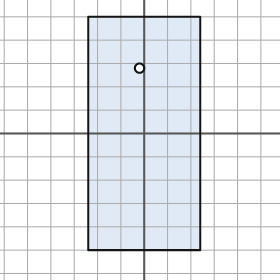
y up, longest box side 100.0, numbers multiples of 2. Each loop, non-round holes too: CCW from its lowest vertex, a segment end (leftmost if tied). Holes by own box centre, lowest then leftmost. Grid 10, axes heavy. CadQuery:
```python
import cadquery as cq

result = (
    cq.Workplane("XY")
    .moveTo(-24.0, -50.0)
    .lineTo(24.0, -50.0)
    .lineTo(24.0, 50.0)
    .lineTo(-24.0, 50.0)
    .close()
    .moveTo(-2.0, 28.0)
    .circle(2.0)
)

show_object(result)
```